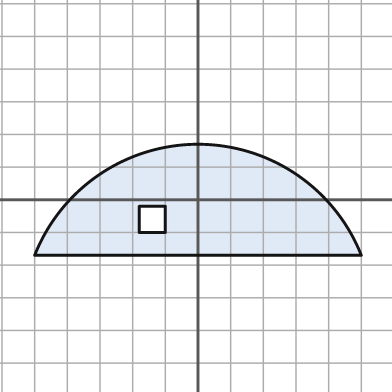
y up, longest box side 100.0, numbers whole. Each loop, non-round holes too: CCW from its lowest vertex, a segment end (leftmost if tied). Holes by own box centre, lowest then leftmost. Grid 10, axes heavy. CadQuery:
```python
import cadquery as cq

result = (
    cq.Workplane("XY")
    .moveTo(-50.0, -17.0)
    .lineTo(50.0, -17.0)
    .threePointArc((0.0, 17.0), (-50.0, -17.0))
    .close()
    .moveTo(-18.0, -10.0)
    .lineTo(-10.0, -10.0)
    .lineTo(-10.0, -2.0)
    .lineTo(-18.0, -2.0)
    .close()
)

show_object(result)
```